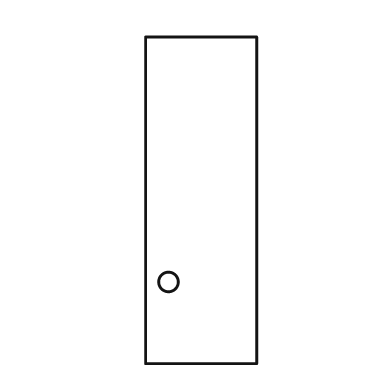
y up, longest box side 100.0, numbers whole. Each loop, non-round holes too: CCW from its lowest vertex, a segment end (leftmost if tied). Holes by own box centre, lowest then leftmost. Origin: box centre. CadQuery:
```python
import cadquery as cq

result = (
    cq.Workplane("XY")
    .moveTo(-17.0, -50.0)
    .lineTo(17.0, -50.0)
    .lineTo(17.0, 50.0)
    .lineTo(-17.0, 50.0)
    .close()
    .moveTo(-10.0, -25.0)
    .circle(3.0)
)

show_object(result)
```